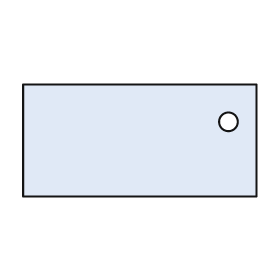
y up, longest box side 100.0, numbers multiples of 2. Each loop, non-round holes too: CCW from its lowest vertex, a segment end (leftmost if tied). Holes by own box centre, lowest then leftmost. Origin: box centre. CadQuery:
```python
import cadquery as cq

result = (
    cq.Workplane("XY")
    .moveTo(-50.0, -24.0)
    .lineTo(50.0, -24.0)
    .lineTo(50.0, 24.0)
    .lineTo(-50.0, 24.0)
    .close()
    .moveTo(38.0, 8.0)
    .circle(4.0)
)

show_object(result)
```